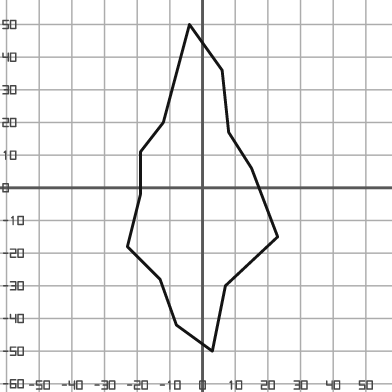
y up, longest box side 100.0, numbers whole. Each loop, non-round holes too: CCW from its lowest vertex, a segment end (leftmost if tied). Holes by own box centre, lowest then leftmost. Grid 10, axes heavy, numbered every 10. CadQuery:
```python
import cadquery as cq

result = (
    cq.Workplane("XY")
    .moveTo(3.0, -50.0)
    .lineTo(7.0, -30.0)
    .lineTo(23.0, -15.0)
    .lineTo(15.0, 6.0)
    .lineTo(8.0, 17.0)
    .lineTo(6.0, 36.0)
    .lineTo(-4.0, 50.0)
    .lineTo(-12.0, 20.0)
    .lineTo(-19.0, 11.0)
    .lineTo(-19.0, -2.0)
    .lineTo(-23.0, -18.0)
    .lineTo(-13.0, -28.0)
    .lineTo(-8.0, -42.0)
    .close()
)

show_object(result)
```